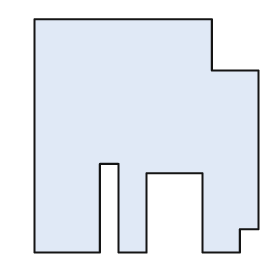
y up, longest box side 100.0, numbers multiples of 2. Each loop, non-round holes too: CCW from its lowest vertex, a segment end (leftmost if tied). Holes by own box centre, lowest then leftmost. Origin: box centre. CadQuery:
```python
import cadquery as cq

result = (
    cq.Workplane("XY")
    .moveTo(-48.0, -50.0)
    .lineTo(-20.0, -50.0)
    .lineTo(-20.0, -12.0)
    .lineTo(-12.0, -12.0)
    .lineTo(-12.0, -50.0)
    .lineTo(0.0, -50.0)
    .lineTo(0.0, -16.0)
    .lineTo(24.0, -16.0)
    .lineTo(24.0, -50.0)
    .lineTo(40.0, -50.0)
    .lineTo(40.0, -40.0)
    .lineTo(48.0, -40.0)
    .lineTo(48.0, 28.0)
    .lineTo(28.0, 28.0)
    .lineTo(28.0, 50.0)
    .lineTo(-48.0, 50.0)
    .close()
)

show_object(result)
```